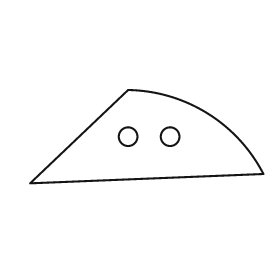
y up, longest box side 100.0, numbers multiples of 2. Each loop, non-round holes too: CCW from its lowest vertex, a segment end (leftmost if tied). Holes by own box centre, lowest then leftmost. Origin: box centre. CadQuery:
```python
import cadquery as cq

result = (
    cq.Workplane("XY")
    .moveTo(-50.0, -20.0)
    .lineTo(50.0, -16.0)
    .threePointArc((26.0, 10.0), (-8.0, 20.0))
    .close()
    .moveTo(-8.0, 0.0)
    .circle(4.0)
    .moveTo(10.0, 0.0)
    .circle(4.0)
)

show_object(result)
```